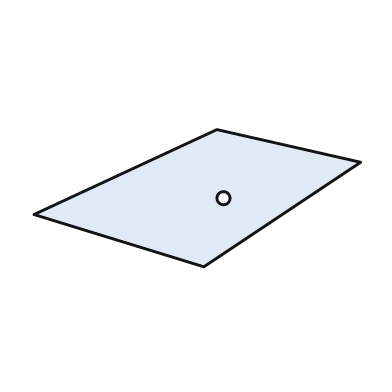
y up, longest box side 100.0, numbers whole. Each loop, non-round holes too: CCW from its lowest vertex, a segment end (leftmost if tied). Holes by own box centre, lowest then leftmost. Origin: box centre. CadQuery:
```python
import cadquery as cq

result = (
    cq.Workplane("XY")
    .moveTo(2.0, -21.0)
    .lineTo(50.0, 11.0)
    .lineTo(6.0, 21.0)
    .lineTo(-50.0, -5.0)
    .close()
    .moveTo(8.0, 0.0)
    .circle(2.0)
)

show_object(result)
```